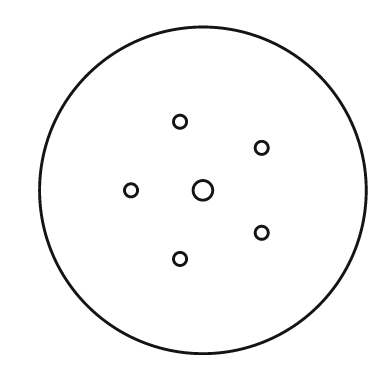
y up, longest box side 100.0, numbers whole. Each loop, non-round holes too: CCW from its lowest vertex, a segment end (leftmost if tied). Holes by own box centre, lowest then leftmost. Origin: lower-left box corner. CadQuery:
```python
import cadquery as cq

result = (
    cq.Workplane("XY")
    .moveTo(50.0, 50.0)
    .circle(50.0)
    .moveTo(43.0, 29.0)
    .circle(2.0)
    .moveTo(68.0, 37.0)
    .circle(2.0)
    .moveTo(28.0, 50.0)
    .circle(2.0)
    .moveTo(50.0, 50.0)
    .circle(3.0)
    .moveTo(68.0, 63.0)
    .circle(2.0)
    .moveTo(43.0, 71.0)
    .circle(2.0)
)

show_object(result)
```